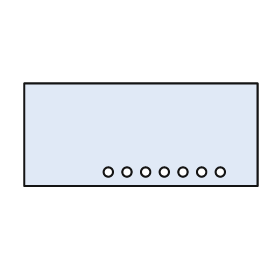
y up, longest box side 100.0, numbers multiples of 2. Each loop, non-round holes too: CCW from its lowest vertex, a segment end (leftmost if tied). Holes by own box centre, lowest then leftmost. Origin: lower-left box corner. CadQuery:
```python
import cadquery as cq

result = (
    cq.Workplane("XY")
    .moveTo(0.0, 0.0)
    .lineTo(100.0, 0.0)
    .lineTo(100.0, 44.0)
    .lineTo(0.0, 44.0)
    .close()
    .moveTo(36.0, 6.0)
    .circle(2.0)
    .moveTo(44.0, 6.0)
    .circle(2.0)
    .moveTo(52.0, 6.0)
    .circle(2.0)
    .moveTo(60.0, 6.0)
    .circle(2.0)
    .moveTo(68.0, 6.0)
    .circle(2.0)
    .moveTo(76.0, 6.0)
    .circle(2.0)
    .moveTo(84.0, 6.0)
    .circle(2.0)
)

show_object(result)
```